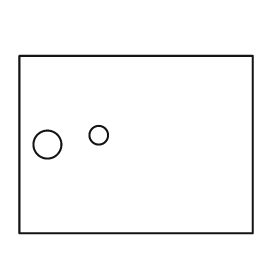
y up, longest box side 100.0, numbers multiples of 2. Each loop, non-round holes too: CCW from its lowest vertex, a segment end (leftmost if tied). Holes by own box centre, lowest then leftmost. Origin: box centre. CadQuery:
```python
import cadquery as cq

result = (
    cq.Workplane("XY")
    .moveTo(-50.0, -38.0)
    .lineTo(50.0, -38.0)
    .lineTo(50.0, 38.0)
    .lineTo(-50.0, 38.0)
    .close()
    .moveTo(-38.0, 0.0)
    .circle(6.0)
    .moveTo(-16.0, 4.0)
    .circle(4.0)
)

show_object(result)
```